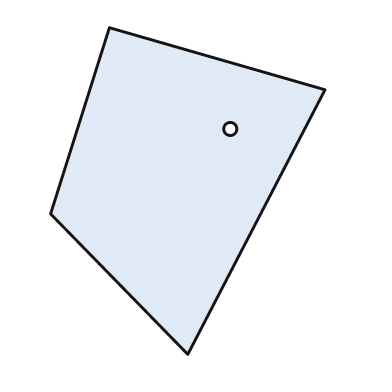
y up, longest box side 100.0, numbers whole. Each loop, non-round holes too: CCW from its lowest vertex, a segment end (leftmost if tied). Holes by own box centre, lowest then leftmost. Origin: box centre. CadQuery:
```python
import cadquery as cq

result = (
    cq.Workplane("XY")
    .moveTo(0.0, -50.0)
    .lineTo(42.0, 31.0)
    .lineTo(-24.0, 50.0)
    .lineTo(-42.0, -7.0)
    .close()
    .moveTo(13.0, 19.0)
    .circle(2.0)
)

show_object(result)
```